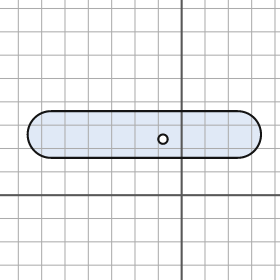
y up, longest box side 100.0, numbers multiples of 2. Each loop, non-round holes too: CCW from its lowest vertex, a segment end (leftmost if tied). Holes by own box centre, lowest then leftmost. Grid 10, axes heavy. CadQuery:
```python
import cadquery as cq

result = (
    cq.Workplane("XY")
    .moveTo(-56.0, 16.0)
    .lineTo(24.0, 16.0)
    .threePointArc((34.0, 26.0), (24.0, 36.0))
    .lineTo(-56.0, 36.0)
    .threePointArc((-66.0, 26.0), (-56.0, 16.0))
    .close()
    .moveTo(-8.0, 24.0)
    .circle(2.0)
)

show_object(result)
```